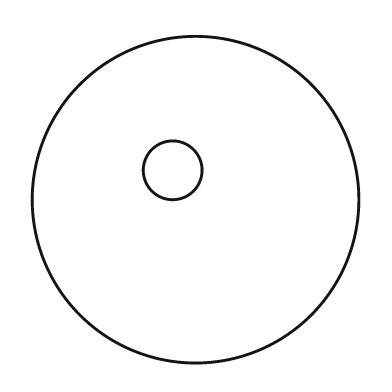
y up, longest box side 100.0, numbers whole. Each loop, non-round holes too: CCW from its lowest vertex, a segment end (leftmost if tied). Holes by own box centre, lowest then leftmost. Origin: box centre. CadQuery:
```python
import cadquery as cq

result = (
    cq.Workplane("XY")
    .moveTo(0.0, 0.0)
    .circle(50.0)
    .moveTo(-7.0, 9.0)
    .circle(9.0)
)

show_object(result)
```